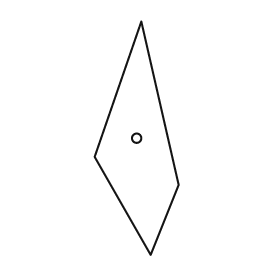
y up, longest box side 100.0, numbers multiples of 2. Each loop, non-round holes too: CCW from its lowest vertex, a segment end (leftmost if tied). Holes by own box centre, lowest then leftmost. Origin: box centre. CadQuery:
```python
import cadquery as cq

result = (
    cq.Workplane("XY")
    .moveTo(6.0, -50.0)
    .lineTo(18.0, -20.0)
    .lineTo(2.0, 50.0)
    .lineTo(-18.0, -8.0)
    .close()
    .moveTo(0.0, 0.0)
    .circle(2.0)
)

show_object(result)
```